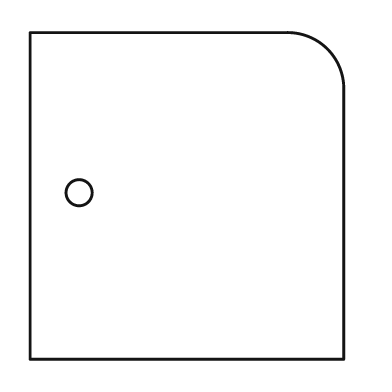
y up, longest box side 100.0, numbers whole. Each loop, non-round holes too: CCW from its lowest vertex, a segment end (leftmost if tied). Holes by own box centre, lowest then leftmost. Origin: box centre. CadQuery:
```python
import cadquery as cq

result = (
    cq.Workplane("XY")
    .moveTo(-48.0, -50.0)
    .lineTo(48.0, -50.0)
    .lineTo(48.0, 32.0)
    .threePointArc((43.0, 45.0), (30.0, 50.0))
    .lineTo(-48.0, 50.0)
    .close()
    .moveTo(-33.0, 1.0)
    .circle(4.0)
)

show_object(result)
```